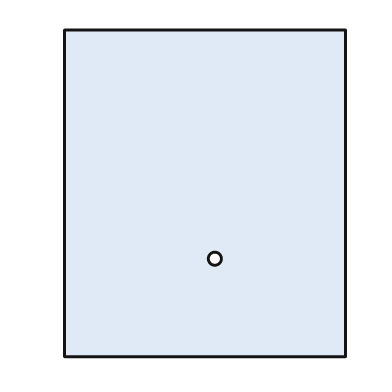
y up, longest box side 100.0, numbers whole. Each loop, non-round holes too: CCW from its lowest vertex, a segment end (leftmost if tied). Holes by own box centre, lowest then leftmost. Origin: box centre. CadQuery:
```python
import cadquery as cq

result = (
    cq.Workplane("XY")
    .moveTo(-43.0, -50.0)
    .lineTo(43.0, -50.0)
    .lineTo(43.0, 50.0)
    .lineTo(-43.0, 50.0)
    .close()
    .moveTo(3.0, -20.0)
    .circle(2.0)
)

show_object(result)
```